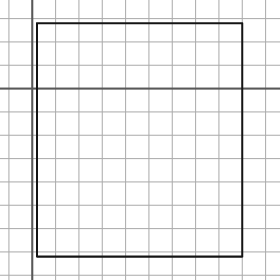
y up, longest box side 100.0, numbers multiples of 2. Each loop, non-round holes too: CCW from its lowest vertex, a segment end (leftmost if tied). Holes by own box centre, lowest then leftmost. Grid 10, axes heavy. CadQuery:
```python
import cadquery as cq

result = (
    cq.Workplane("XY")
    .moveTo(2.0, -72.0)
    .lineTo(90.0, -72.0)
    .lineTo(90.0, 28.0)
    .lineTo(2.0, 28.0)
    .close()
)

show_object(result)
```